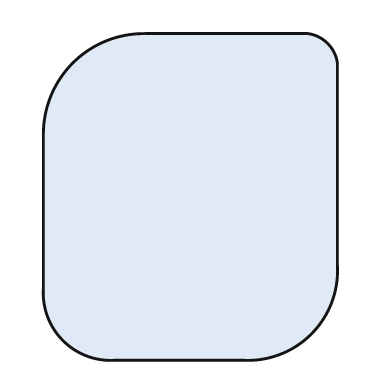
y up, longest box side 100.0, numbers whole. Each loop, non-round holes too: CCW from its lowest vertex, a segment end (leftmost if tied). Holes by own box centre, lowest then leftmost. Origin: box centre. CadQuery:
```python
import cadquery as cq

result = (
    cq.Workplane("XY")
    .moveTo(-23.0, -50.0)
    .lineTo(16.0, -50.0)
    .threePointArc((37.0, -42.0), (45.0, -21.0))
    .lineTo(45.0, 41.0)
    .threePointArc((42.0, 47.0), (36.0, 50.0))
    .lineTo(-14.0, 50.0)
    .threePointArc((-36.0, 41.0), (-45.0, 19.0))
    .lineTo(-45.0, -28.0)
    .threePointArc((-39.0, -44.0), (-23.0, -50.0))
    .close()
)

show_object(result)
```